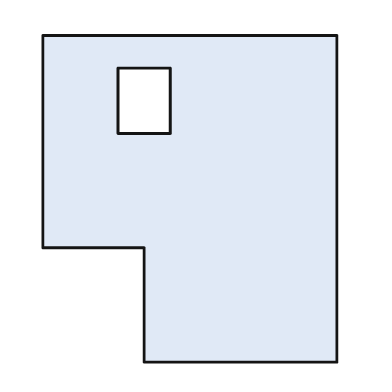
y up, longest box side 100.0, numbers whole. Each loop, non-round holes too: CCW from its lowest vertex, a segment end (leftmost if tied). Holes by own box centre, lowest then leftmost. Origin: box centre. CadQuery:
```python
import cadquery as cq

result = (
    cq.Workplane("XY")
    .moveTo(-14.0, -50.0)
    .lineTo(45.0, -50.0)
    .lineTo(45.0, 50.0)
    .lineTo(-45.0, 50.0)
    .lineTo(-45.0, -15.0)
    .lineTo(-14.0, -15.0)
    .close()
    .moveTo(-22.0, 20.0)
    .lineTo(-6.0, 20.0)
    .lineTo(-6.0, 40.0)
    .lineTo(-22.0, 40.0)
    .close()
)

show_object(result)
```